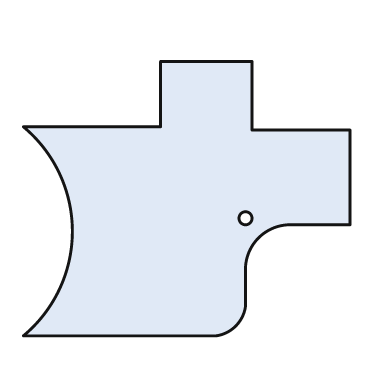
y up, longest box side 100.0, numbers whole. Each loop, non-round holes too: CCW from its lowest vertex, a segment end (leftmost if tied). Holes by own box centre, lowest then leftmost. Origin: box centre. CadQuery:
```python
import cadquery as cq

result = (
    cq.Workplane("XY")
    .moveTo(-50.0, -42.0)
    .lineTo(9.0, -42.0)
    .threePointArc((15.0, -39.0), (18.0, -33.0))
    .lineTo(18.0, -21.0)
    .threePointArc((22.0, -12.0), (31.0, -8.0))
    .lineTo(50.0, -8.0)
    .lineTo(50.0, 21.0)
    .lineTo(20.0, 21.0)
    .lineTo(20.0, 42.0)
    .lineTo(-8.0, 42.0)
    .lineTo(-8.0, 22.0)
    .lineTo(-50.0, 22.0)
    .threePointArc((-35.0, -10.0), (-50.0, -42.0))
    .close()
    .moveTo(18.0, -6.0)
    .circle(2.0)
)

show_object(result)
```